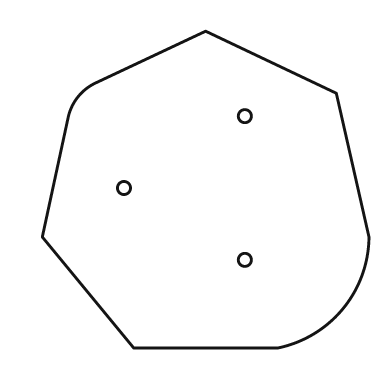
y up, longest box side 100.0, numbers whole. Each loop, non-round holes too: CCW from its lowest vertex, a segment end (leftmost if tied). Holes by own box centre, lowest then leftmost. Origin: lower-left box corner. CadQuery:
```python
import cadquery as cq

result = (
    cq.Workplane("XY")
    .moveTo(28.0, 0.0)
    .lineTo(72.0, 0.0)
    .threePointArc((92.0, 12.0), (100.0, 34.0))
    .lineTo(90.0, 78.0)
    .lineTo(50.0, 97.0)
    .lineTo(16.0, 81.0)
    .threePointArc((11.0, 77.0), (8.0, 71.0))
    .lineTo(0.0, 34.0)
    .close()
    .moveTo(62.0, 27.0)
    .circle(2.0)
    .moveTo(25.0, 49.0)
    .circle(2.0)
    .moveTo(62.0, 71.0)
    .circle(2.0)
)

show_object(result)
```